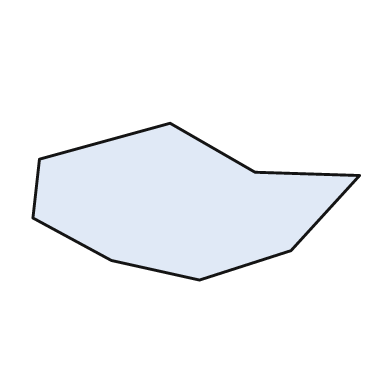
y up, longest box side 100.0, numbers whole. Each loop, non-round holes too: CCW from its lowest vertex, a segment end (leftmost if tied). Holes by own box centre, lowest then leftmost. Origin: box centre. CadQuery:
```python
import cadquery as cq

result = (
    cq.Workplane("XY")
    .moveTo(1.0, -24.0)
    .lineTo(29.0, -15.0)
    .lineTo(50.0, 8.0)
    .lineTo(18.0, 9.0)
    .lineTo(-8.0, 24.0)
    .lineTo(-48.0, 13.0)
    .lineTo(-50.0, -5.0)
    .lineTo(-26.0, -18.0)
    .close()
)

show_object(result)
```